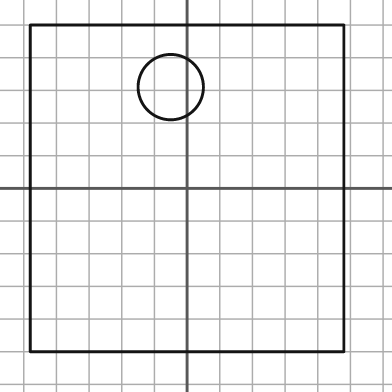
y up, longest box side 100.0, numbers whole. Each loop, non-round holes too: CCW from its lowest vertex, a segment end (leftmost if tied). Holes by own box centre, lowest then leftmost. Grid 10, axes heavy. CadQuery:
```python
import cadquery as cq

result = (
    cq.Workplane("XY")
    .moveTo(-48.0, -50.0)
    .lineTo(48.0, -50.0)
    .lineTo(48.0, 50.0)
    .lineTo(-48.0, 50.0)
    .close()
    .moveTo(-5.0, 31.0)
    .circle(10.0)
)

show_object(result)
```